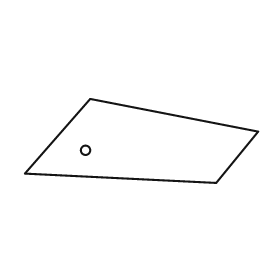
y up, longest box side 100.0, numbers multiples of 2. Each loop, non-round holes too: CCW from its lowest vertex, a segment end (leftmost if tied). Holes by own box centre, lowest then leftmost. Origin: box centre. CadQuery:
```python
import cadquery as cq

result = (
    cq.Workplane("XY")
    .moveTo(32.0, -18.0)
    .lineTo(50.0, 4.0)
    .lineTo(-22.0, 18.0)
    .lineTo(-50.0, -14.0)
    .close()
    .moveTo(-24.0, -4.0)
    .circle(2.0)
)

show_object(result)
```